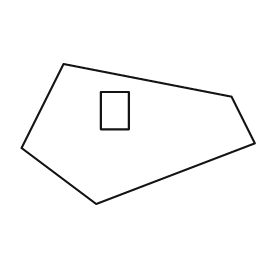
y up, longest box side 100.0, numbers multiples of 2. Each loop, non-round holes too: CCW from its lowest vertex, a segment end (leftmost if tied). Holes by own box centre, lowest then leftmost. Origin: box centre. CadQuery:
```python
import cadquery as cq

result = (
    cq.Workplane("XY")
    .moveTo(-18.0, -30.0)
    .lineTo(50.0, -4.0)
    .lineTo(40.0, 16.0)
    .lineTo(-32.0, 30.0)
    .lineTo(-50.0, -6.0)
    .close()
    .moveTo(-16.0, 2.0)
    .lineTo(-4.0, 2.0)
    .lineTo(-4.0, 18.0)
    .lineTo(-16.0, 18.0)
    .close()
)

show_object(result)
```